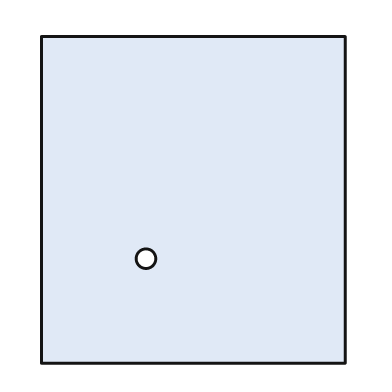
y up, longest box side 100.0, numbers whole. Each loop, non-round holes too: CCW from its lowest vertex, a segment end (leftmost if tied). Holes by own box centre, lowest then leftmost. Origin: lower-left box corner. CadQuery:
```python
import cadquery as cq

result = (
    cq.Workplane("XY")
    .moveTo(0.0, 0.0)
    .lineTo(93.0, 0.0)
    .lineTo(93.0, 100.0)
    .lineTo(0.0, 100.0)
    .close()
    .moveTo(32.0, 32.0)
    .circle(3.0)
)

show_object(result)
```